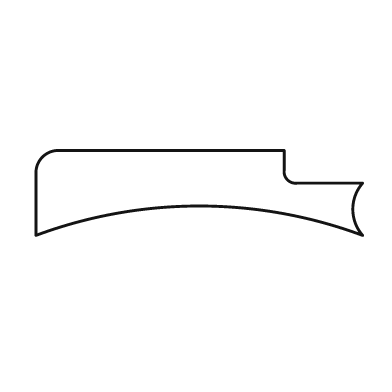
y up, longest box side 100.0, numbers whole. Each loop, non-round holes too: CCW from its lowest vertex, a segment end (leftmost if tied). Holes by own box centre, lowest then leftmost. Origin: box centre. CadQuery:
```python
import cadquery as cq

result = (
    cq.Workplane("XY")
    .moveTo(-50.0, -13.0)
    .threePointArc((0.0, -4.0), (50.0, -13.0))
    .threePointArc((47.0, -5.0), (50.0, 3.0))
    .lineTo(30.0, 3.0)
    .threePointArc((27.0, 4.0), (26.0, 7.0))
    .lineTo(26.0, 13.0)
    .lineTo(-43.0, 13.0)
    .threePointArc((-48.0, 11.0), (-50.0, 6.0))
    .close()
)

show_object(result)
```